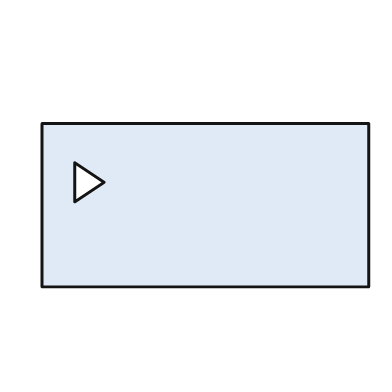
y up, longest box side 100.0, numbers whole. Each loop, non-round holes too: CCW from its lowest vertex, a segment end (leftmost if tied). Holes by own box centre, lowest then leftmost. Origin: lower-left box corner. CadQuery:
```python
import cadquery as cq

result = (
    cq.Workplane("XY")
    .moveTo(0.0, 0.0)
    .lineTo(100.0, 0.0)
    .lineTo(100.0, 50.0)
    .lineTo(0.0, 50.0)
    .close()
    .moveTo(10.0, 26.0)
    .lineTo(19.0, 32.0)
    .lineTo(10.0, 38.0)
    .close()
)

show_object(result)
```